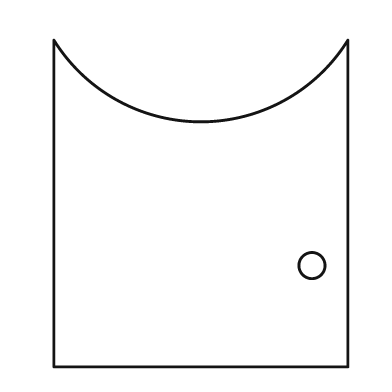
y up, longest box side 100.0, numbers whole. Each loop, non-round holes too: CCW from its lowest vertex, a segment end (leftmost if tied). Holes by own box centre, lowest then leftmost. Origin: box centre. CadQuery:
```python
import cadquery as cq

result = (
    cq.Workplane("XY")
    .moveTo(-45.0, -50.0)
    .lineTo(45.0, -50.0)
    .lineTo(45.0, 50.0)
    .threePointArc((0.0, 25.0), (-45.0, 50.0))
    .close()
    .moveTo(34.0, -19.0)
    .circle(4.0)
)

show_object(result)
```